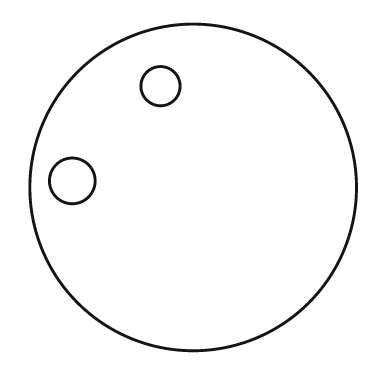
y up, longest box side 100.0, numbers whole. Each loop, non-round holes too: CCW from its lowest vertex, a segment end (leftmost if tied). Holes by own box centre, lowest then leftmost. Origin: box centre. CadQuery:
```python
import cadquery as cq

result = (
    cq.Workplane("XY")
    .moveTo(0.0, 0.0)
    .circle(50.0)
    .moveTo(-37.0, 2.0)
    .circle(7.0)
    .moveTo(-10.0, 31.0)
    .circle(6.0)
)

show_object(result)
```